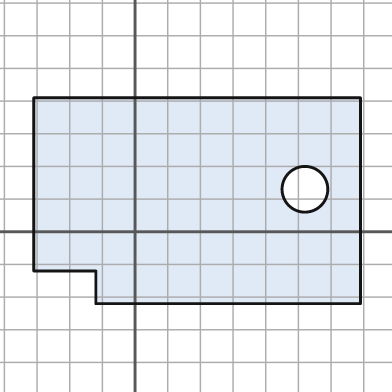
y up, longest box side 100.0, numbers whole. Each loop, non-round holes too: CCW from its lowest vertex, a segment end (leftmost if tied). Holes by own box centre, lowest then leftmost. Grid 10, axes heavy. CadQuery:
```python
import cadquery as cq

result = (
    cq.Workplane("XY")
    .moveTo(-12.0, -22.0)
    .lineTo(69.0, -22.0)
    .lineTo(69.0, 41.0)
    .lineTo(-31.0, 41.0)
    .lineTo(-31.0, -12.0)
    .lineTo(-12.0, -12.0)
    .close()
    .moveTo(52.0, 13.0)
    .circle(7.0)
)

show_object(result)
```